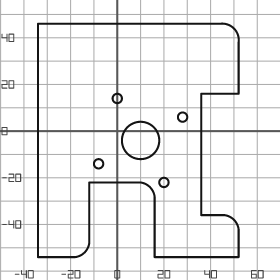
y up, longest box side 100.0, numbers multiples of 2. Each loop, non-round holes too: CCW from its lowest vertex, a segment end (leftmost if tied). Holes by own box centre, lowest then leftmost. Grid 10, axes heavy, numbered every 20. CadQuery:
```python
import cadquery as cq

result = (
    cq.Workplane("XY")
    .moveTo(-34.0, -54.0)
    .lineTo(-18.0, -54.0)
    .threePointArc((-14.0, -52.0), (-12.0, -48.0))
    .lineTo(-12.0, -22.0)
    .lineTo(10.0, -22.0)
    .threePointArc((14.0, -24.0), (16.0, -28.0))
    .lineTo(16.0, -54.0)
    .lineTo(52.0, -54.0)
    .lineTo(52.0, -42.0)
    .threePointArc((50.0, -38.0), (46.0, -36.0))
    .lineTo(36.0, -36.0)
    .lineTo(36.0, 16.0)
    .lineTo(52.0, 16.0)
    .lineTo(52.0, 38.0)
    .threePointArc((50.0, 44.0), (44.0, 46.0))
    .lineTo(-34.0, 46.0)
    .close()
    .moveTo(20.0, -22.0)
    .circle(2.0)
    .moveTo(-8.0, -14.0)
    .circle(2.0)
    .moveTo(10.0, -4.0)
    .circle(8.0)
    .moveTo(28.0, 6.0)
    .circle(2.0)
    .moveTo(0.0, 14.0)
    .circle(2.0)
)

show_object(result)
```